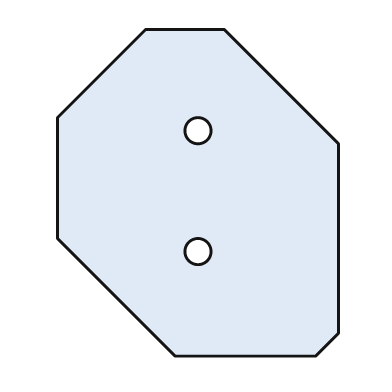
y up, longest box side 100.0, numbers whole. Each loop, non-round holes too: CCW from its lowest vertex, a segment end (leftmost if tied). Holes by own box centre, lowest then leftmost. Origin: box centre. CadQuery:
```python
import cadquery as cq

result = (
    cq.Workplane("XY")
    .moveTo(-7.0, -50.0)
    .lineTo(36.0, -50.0)
    .lineTo(43.0, -43.0)
    .lineTo(43.0, 15.0)
    .lineTo(8.0, 50.0)
    .lineTo(-16.0, 50.0)
    .lineTo(-43.0, 23.0)
    .lineTo(-43.0, -14.0)
    .close()
    .moveTo(0.0, -18.0)
    .circle(4.0)
    .moveTo(0.0, 19.0)
    .circle(4.0)
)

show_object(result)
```